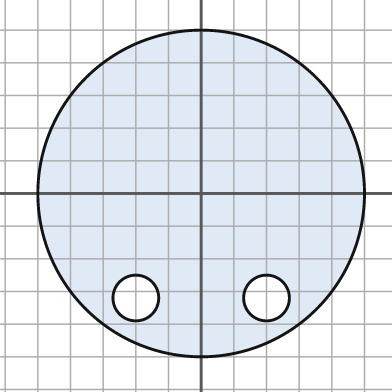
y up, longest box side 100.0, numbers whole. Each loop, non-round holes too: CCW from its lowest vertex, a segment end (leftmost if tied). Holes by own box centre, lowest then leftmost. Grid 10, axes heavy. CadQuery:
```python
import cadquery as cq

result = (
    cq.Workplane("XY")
    .moveTo(0.0, 0.0)
    .circle(50.0)
    .moveTo(-20.0, -32.0)
    .circle(7.0)
    .moveTo(20.0, -32.0)
    .circle(7.0)
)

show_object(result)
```